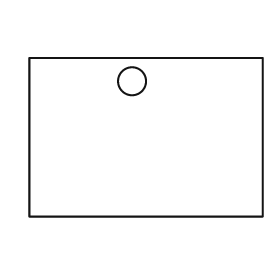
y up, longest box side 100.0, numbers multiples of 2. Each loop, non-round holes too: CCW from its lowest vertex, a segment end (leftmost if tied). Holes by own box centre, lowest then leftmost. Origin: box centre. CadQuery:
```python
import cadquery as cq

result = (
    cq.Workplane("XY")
    .moveTo(-50.0, -34.0)
    .lineTo(50.0, -34.0)
    .lineTo(50.0, 34.0)
    .lineTo(-50.0, 34.0)
    .close()
    .moveTo(-6.0, 24.0)
    .circle(6.0)
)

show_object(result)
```